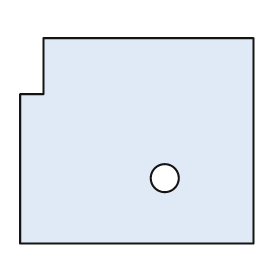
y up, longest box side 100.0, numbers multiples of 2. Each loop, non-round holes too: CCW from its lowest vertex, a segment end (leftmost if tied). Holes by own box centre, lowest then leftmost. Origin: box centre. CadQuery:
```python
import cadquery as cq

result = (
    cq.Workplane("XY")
    .moveTo(-50.0, -44.0)
    .lineTo(50.0, -44.0)
    .lineTo(50.0, 44.0)
    .lineTo(-40.0, 44.0)
    .lineTo(-40.0, 20.0)
    .lineTo(-50.0, 20.0)
    .close()
    .moveTo(12.0, -16.0)
    .circle(6.0)
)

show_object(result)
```